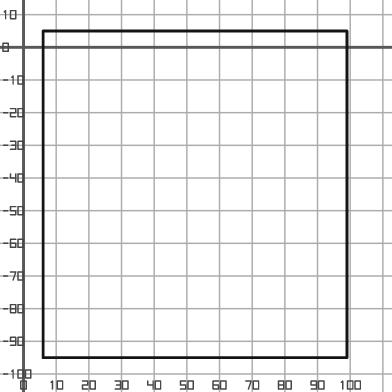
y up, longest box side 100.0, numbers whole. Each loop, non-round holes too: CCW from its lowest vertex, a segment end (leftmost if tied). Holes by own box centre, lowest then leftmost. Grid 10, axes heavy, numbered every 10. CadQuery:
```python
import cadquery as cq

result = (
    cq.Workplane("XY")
    .moveTo(6.0, -95.0)
    .lineTo(99.0, -95.0)
    .lineTo(99.0, 5.0)
    .lineTo(6.0, 5.0)
    .close()
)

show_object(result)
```